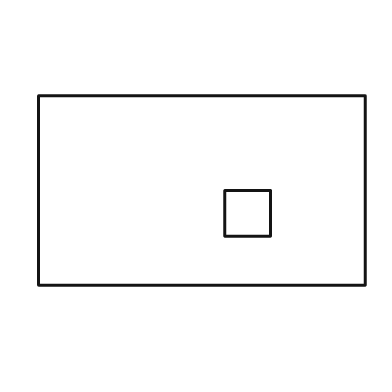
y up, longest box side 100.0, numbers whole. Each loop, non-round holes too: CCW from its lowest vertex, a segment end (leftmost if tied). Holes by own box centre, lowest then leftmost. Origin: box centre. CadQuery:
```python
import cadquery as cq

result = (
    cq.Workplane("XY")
    .moveTo(-50.0, -29.0)
    .lineTo(50.0, -29.0)
    .lineTo(50.0, 29.0)
    .lineTo(-50.0, 29.0)
    .close()
    .moveTo(7.0, -14.0)
    .lineTo(21.0, -14.0)
    .lineTo(21.0, 0.0)
    .lineTo(7.0, 0.0)
    .close()
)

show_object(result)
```